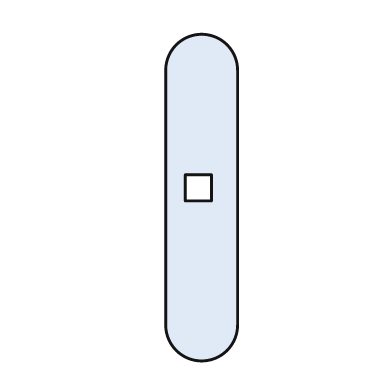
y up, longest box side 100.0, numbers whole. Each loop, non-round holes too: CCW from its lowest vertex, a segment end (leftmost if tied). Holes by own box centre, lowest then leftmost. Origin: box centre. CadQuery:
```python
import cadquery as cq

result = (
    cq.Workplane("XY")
    .moveTo(-11.0, -39.0)
    .threePointArc((0.0, -50.0), (11.0, -39.0))
    .lineTo(11.0, 39.0)
    .threePointArc((0.0, 50.0), (-11.0, 39.0))
    .close()
    .moveTo(-5.0, -1.0)
    .lineTo(3.0, -1.0)
    .lineTo(3.0, 7.0)
    .lineTo(-5.0, 7.0)
    .close()
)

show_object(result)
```